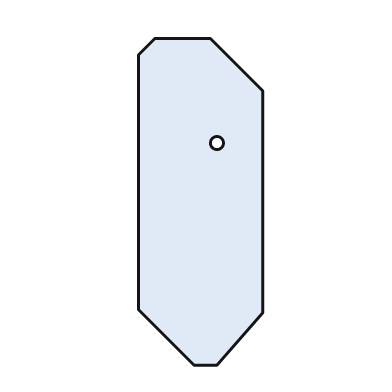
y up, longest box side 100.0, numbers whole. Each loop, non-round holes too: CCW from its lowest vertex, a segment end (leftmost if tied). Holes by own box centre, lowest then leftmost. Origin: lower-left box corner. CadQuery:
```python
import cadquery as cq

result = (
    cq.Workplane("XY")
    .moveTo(17.0, 0.0)
    .lineTo(24.0, 0.0)
    .lineTo(38.0, 16.0)
    .lineTo(38.0, 84.0)
    .lineTo(22.0, 100.0)
    .lineTo(5.0, 100.0)
    .lineTo(0.0, 95.0)
    .lineTo(0.0, 17.0)
    .close()
    .moveTo(24.0, 68.0)
    .circle(2.0)
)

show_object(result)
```